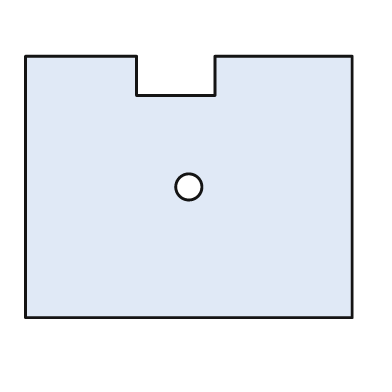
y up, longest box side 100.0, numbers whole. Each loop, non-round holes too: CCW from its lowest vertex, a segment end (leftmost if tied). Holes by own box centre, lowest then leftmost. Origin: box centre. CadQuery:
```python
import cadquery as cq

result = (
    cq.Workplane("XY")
    .moveTo(-50.0, -40.0)
    .lineTo(50.0, -40.0)
    .lineTo(50.0, 40.0)
    .lineTo(8.0, 40.0)
    .lineTo(8.0, 28.0)
    .lineTo(-16.0, 28.0)
    .lineTo(-16.0, 40.0)
    .lineTo(-50.0, 40.0)
    .close()
    .moveTo(0.0, 0.0)
    .circle(4.0)
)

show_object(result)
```